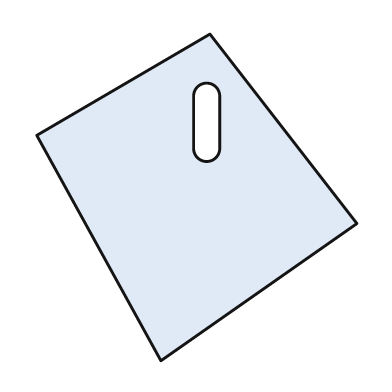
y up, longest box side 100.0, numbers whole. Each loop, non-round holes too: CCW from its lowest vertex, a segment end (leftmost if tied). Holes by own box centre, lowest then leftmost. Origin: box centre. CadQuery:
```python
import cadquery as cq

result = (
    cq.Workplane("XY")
    .moveTo(-11.0, -50.0)
    .lineTo(49.0, -8.0)
    .lineTo(4.0, 50.0)
    .lineTo(-49.0, 19.0)
    .close()
    .moveTo(-1.0, 15.0)
    .threePointArc((3.0, 11.0), (7.0, 15.0))
    .lineTo(7.0, 31.0)
    .threePointArc((3.0, 35.0), (-1.0, 31.0))
    .close()
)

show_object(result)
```